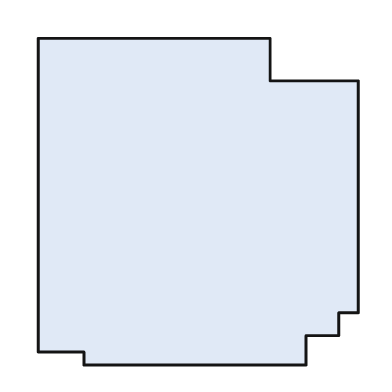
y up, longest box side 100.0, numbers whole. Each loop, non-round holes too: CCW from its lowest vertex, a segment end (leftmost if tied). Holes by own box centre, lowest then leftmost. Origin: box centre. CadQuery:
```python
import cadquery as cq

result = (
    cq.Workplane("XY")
    .moveTo(-35.0, -50.0)
    .lineTo(33.0, -50.0)
    .lineTo(33.0, -41.0)
    .lineTo(43.0, -41.0)
    .lineTo(43.0, -34.0)
    .lineTo(49.0, -34.0)
    .lineTo(49.0, 37.0)
    .lineTo(22.0, 37.0)
    .lineTo(22.0, 50.0)
    .lineTo(-49.0, 50.0)
    .lineTo(-49.0, -46.0)
    .lineTo(-35.0, -46.0)
    .close()
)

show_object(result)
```